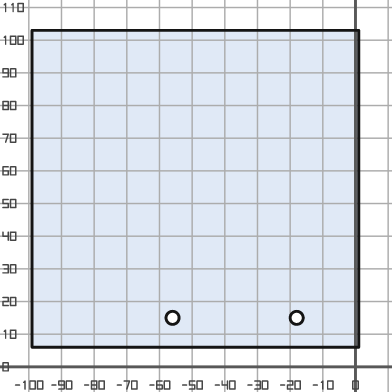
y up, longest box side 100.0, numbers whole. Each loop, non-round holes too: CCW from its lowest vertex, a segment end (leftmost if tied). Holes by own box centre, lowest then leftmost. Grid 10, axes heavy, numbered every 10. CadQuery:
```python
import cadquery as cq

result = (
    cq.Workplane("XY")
    .moveTo(-99.0, 6.0)
    .lineTo(1.0, 6.0)
    .lineTo(1.0, 103.0)
    .lineTo(-99.0, 103.0)
    .close()
    .moveTo(-56.0, 15.0)
    .circle(2.0)
    .moveTo(-18.0, 15.0)
    .circle(2.0)
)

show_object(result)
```